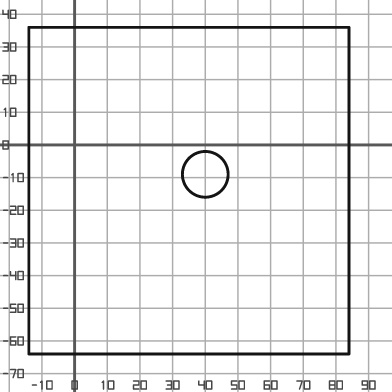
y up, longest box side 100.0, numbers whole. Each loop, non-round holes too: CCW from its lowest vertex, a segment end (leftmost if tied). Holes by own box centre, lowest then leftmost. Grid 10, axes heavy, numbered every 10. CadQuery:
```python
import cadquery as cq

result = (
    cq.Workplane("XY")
    .moveTo(-14.0, -64.0)
    .lineTo(84.0, -64.0)
    .lineTo(84.0, 36.0)
    .lineTo(-14.0, 36.0)
    .close()
    .moveTo(40.0, -9.0)
    .circle(7.0)
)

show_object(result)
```